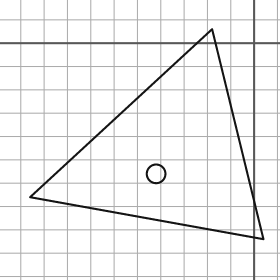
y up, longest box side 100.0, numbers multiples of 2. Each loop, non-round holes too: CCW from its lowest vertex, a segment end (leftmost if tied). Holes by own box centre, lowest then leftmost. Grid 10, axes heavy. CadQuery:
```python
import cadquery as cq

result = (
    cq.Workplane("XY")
    .moveTo(4.0, -84.0)
    .lineTo(-18.0, 6.0)
    .lineTo(-96.0, -66.0)
    .close()
    .moveTo(-42.0, -56.0)
    .circle(4.0)
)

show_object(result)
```